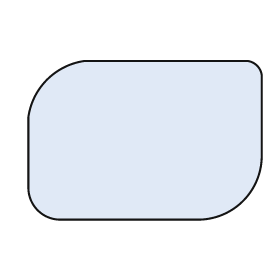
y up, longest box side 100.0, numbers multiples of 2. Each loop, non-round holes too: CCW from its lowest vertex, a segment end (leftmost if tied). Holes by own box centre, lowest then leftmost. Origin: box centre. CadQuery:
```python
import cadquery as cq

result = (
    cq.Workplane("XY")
    .moveTo(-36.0, -34.0)
    .lineTo(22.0, -34.0)
    .threePointArc((42.0, -26.0), (50.0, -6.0))
    .lineTo(50.0, 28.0)
    .threePointArc((48.0, 32.0), (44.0, 34.0))
    .lineTo(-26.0, 34.0)
    .threePointArc((-42.0, 26.0), (-50.0, 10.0))
    .lineTo(-50.0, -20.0)
    .threePointArc((-46.0, -30.0), (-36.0, -34.0))
    .close()
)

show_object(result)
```